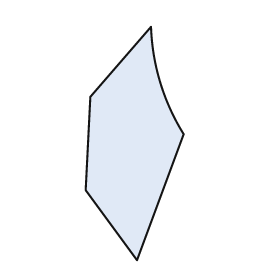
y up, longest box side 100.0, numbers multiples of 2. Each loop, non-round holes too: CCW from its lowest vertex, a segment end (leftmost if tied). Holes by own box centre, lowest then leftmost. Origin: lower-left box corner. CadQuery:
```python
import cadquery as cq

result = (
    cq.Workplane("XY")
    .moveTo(22.0, 0.0)
    .lineTo(42.0, 54.0)
    .threePointArc((32.0, 76.0), (28.0, 100.0))
    .lineTo(2.0, 70.0)
    .lineTo(0.0, 30.0)
    .close()
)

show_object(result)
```